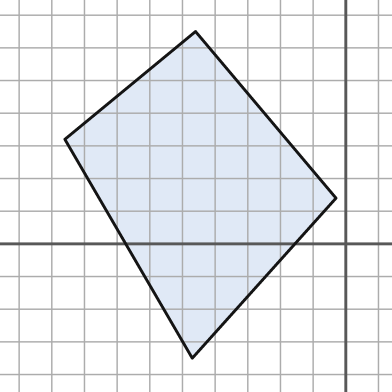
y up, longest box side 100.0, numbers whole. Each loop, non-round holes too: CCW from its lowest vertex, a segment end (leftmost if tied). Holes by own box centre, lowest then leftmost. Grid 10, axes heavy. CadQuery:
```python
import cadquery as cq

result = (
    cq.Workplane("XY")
    .moveTo(-47.0, -35.0)
    .lineTo(-3.0, 14.0)
    .lineTo(-46.0, 65.0)
    .lineTo(-86.0, 32.0)
    .close()
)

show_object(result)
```